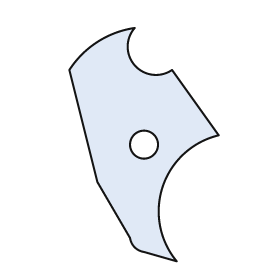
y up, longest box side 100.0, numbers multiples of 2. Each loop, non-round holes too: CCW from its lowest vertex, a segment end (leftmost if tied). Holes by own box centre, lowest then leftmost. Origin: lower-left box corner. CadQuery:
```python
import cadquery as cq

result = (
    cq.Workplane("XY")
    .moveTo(46.0, 0.0)
    .threePointArc((40.0, 32.0), (64.0, 54.0))
    .lineTo(44.0, 82.0)
    .threePointArc((28.0, 84.0), (28.0, 100.0))
    .threePointArc((12.0, 94.0), (0.0, 82.0))
    .lineTo(12.0, 34.0)
    .lineTo(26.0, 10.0)
    .threePointArc((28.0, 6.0), (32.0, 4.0))
    .close()
    .moveTo(32.0, 50.0)
    .circle(6.0)
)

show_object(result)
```